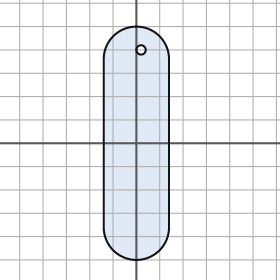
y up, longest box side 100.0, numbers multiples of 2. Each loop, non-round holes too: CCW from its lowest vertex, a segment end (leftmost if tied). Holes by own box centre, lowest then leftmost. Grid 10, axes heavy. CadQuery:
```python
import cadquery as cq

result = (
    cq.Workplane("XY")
    .moveTo(-14.0, -36.0)
    .threePointArc((0.0, -50.0), (14.0, -36.0))
    .lineTo(14.0, 36.0)
    .threePointArc((0.0, 50.0), (-14.0, 36.0))
    .close()
    .moveTo(2.0, 40.0)
    .circle(2.0)
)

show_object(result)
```